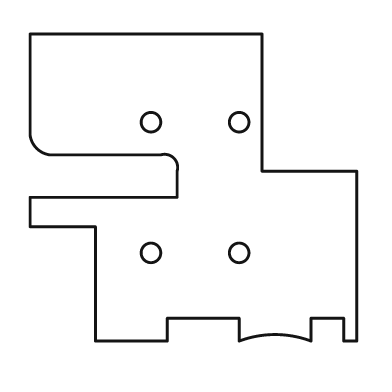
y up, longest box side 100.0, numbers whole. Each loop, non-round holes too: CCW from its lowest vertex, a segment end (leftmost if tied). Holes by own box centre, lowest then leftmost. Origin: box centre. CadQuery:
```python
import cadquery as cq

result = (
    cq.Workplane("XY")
    .moveTo(-30.0, -47.0)
    .lineTo(-8.0, -47.0)
    .lineTo(-8.0, -40.0)
    .lineTo(14.0, -40.0)
    .lineTo(14.0, -47.0)
    .threePointArc((25.0, -45.0), (36.0, -47.0))
    .lineTo(36.0, -40.0)
    .lineTo(46.0, -40.0)
    .lineTo(46.0, -47.0)
    .lineTo(50.0, -47.0)
    .lineTo(50.0, 5.0)
    .lineTo(21.0, 5.0)
    .lineTo(21.0, 47.0)
    .lineTo(-50.0, 47.0)
    .lineTo(-50.0, 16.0)
    .threePointArc((-48.0, 12.0), (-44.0, 10.0))
    .lineTo(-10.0, 10.0)
    .threePointArc((-6.0, 9.0), (-5.0, 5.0))
    .lineTo(-5.0, -3.0)
    .lineTo(-50.0, -3.0)
    .lineTo(-50.0, -12.0)
    .lineTo(-30.0, -12.0)
    .close()
    .moveTo(-13.0, -20.0)
    .circle(3.0)
    .moveTo(14.0, -20.0)
    .circle(3.0)
    .moveTo(-13.0, 20.0)
    .circle(3.0)
    .moveTo(14.0, 20.0)
    .circle(3.0)
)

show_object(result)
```